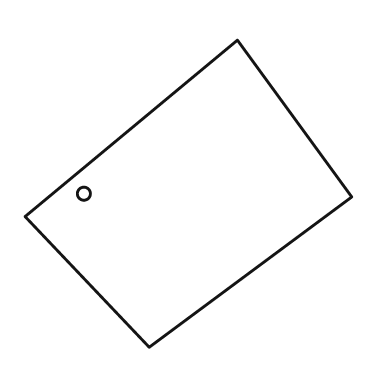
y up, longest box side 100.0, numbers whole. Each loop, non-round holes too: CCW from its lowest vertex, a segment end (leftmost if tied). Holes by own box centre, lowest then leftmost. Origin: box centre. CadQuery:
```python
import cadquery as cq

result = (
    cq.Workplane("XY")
    .moveTo(-12.0, -47.0)
    .lineTo(50.0, -1.0)
    .lineTo(15.0, 47.0)
    .lineTo(-50.0, -7.0)
    .close()
    .moveTo(-32.0, 0.0)
    .circle(2.0)
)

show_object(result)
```